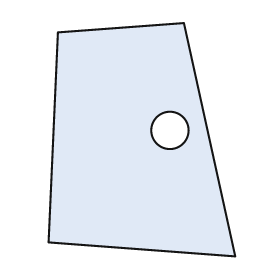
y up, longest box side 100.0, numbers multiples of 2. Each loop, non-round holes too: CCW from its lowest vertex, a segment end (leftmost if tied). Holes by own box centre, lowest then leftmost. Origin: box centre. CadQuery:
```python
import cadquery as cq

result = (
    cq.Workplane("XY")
    .moveTo(40.0, -50.0)
    .lineTo(18.0, 50.0)
    .lineTo(-36.0, 46.0)
    .lineTo(-40.0, -44.0)
    .close()
    .moveTo(12.0, 4.0)
    .circle(8.0)
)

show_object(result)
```